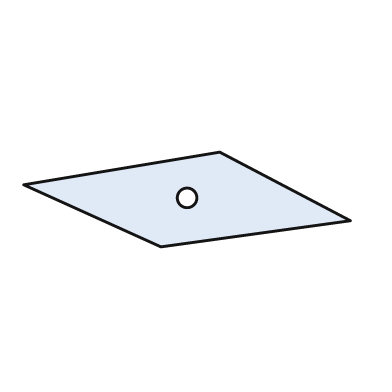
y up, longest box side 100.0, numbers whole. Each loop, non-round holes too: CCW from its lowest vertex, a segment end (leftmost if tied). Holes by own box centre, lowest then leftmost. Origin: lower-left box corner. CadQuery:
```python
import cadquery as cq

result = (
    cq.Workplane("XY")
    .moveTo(42.0, 0.0)
    .lineTo(100.0, 8.0)
    .lineTo(60.0, 29.0)
    .lineTo(0.0, 19.0)
    .close()
    .moveTo(50.0, 15.0)
    .circle(3.0)
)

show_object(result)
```